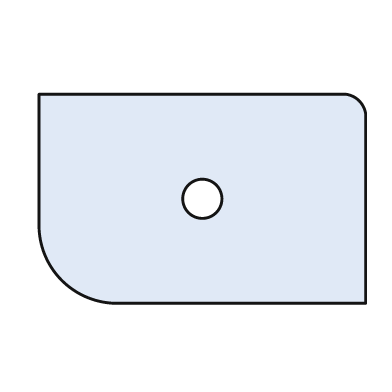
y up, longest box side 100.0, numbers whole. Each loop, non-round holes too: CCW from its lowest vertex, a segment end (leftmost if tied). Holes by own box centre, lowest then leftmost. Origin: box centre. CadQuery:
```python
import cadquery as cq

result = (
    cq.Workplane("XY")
    .moveTo(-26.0, -32.0)
    .lineTo(50.0, -32.0)
    .lineTo(50.0, 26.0)
    .threePointArc((48.0, 30.0), (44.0, 32.0))
    .lineTo(-50.0, 32.0)
    .lineTo(-50.0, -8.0)
    .threePointArc((-43.0, -25.0), (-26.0, -32.0))
    .close()
    .moveTo(0.0, 0.0)
    .circle(6.0)
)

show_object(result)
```